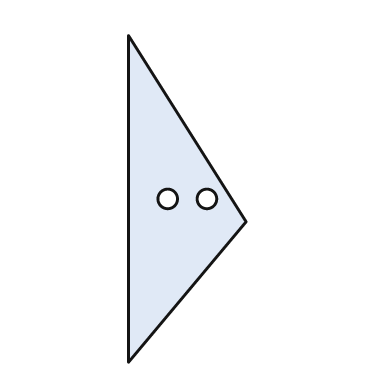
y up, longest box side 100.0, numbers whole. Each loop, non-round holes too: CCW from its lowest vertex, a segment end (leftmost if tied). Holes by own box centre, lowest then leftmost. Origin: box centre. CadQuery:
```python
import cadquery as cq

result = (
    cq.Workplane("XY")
    .moveTo(-18.0, -50.0)
    .lineTo(18.0, -7.0)
    .lineTo(-18.0, 50.0)
    .close()
    .moveTo(-6.0, 0.0)
    .circle(3.0)
    .moveTo(6.0, 0.0)
    .circle(3.0)
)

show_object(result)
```